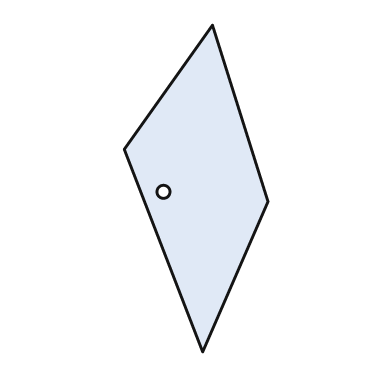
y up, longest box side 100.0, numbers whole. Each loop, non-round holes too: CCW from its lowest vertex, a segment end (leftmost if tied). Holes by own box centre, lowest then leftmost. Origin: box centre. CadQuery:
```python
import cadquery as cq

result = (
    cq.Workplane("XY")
    .moveTo(2.0, -50.0)
    .lineTo(22.0, -4.0)
    .lineTo(5.0, 50.0)
    .lineTo(-22.0, 12.0)
    .close()
    .moveTo(-10.0, -1.0)
    .circle(2.0)
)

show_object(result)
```